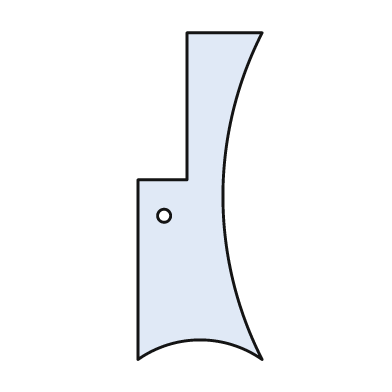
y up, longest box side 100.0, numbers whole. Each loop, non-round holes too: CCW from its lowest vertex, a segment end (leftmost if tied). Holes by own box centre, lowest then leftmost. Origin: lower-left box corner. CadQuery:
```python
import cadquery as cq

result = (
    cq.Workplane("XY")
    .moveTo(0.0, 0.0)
    .threePointArc((19.0, 6.0), (38.0, 0.0))
    .threePointArc((26.0, 50.0), (38.0, 100.0))
    .lineTo(15.0, 100.0)
    .lineTo(15.0, 55.0)
    .lineTo(0.0, 55.0)
    .close()
    .moveTo(8.0, 44.0)
    .circle(2.0)
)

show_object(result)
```